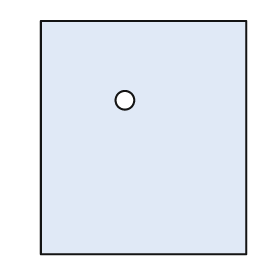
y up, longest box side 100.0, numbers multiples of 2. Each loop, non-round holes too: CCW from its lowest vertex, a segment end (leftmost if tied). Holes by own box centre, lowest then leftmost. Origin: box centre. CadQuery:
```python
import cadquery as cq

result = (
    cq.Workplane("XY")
    .moveTo(-44.0, -50.0)
    .lineTo(44.0, -50.0)
    .lineTo(44.0, 50.0)
    .lineTo(-44.0, 50.0)
    .close()
    .moveTo(-8.0, 16.0)
    .circle(4.0)
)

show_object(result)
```